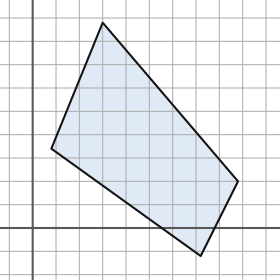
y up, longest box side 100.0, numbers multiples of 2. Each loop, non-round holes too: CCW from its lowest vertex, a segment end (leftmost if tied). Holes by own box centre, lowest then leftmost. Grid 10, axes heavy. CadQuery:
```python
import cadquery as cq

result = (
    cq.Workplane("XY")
    .moveTo(72.0, -12.0)
    .lineTo(88.0, 20.0)
    .lineTo(30.0, 88.0)
    .lineTo(8.0, 34.0)
    .close()
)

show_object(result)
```